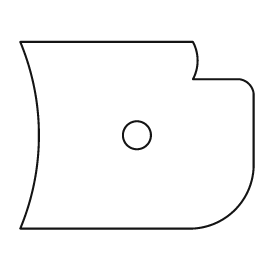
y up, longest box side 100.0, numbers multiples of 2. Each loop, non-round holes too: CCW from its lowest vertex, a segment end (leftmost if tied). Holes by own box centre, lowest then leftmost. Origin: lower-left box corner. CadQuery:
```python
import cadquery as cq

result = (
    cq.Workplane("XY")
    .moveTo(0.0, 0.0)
    .lineTo(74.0, 0.0)
    .threePointArc((92.0, 8.0), (100.0, 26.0))
    .lineTo(100.0, 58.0)
    .threePointArc((98.0, 62.0), (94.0, 64.0))
    .lineTo(74.0, 64.0)
    .threePointArc((76.0, 72.0), (74.0, 80.0))
    .lineTo(0.0, 80.0)
    .threePointArc((8.0, 40.0), (0.0, 0.0))
    .close()
    .moveTo(50.0, 40.0)
    .circle(6.0)
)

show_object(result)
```